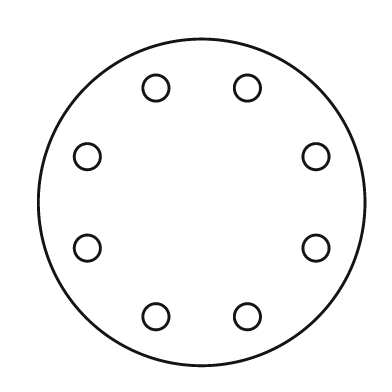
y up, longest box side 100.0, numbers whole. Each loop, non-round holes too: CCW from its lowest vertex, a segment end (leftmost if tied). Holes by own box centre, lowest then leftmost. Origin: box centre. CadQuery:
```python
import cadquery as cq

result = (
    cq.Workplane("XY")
    .moveTo(0.0, 0.0)
    .circle(50.0)
    .moveTo(-14.0, -35.0)
    .circle(4.0)
    .moveTo(14.0, -35.0)
    .circle(4.0)
    .moveTo(-35.0, -14.0)
    .circle(4.0)
    .moveTo(35.0, -14.0)
    .circle(4.0)
    .moveTo(-35.0, 14.0)
    .circle(4.0)
    .moveTo(35.0, 14.0)
    .circle(4.0)
    .moveTo(-14.0, 35.0)
    .circle(4.0)
    .moveTo(14.0, 35.0)
    .circle(4.0)
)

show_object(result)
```